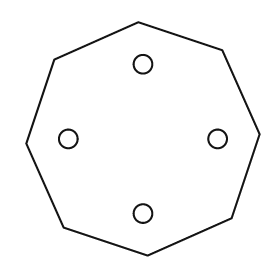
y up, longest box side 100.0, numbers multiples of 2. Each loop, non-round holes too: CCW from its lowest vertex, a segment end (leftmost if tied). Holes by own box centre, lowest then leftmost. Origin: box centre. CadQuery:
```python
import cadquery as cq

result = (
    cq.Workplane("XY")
    .moveTo(2.0, -50.0)
    .lineTo(38.0, -34.0)
    .lineTo(50.0, 2.0)
    .lineTo(34.0, 38.0)
    .lineTo(-2.0, 50.0)
    .lineTo(-38.0, 34.0)
    .lineTo(-50.0, -2.0)
    .lineTo(-34.0, -38.0)
    .close()
    .moveTo(0.0, -32.0)
    .circle(4.0)
    .moveTo(-32.0, 0.0)
    .circle(4.0)
    .moveTo(32.0, 0.0)
    .circle(4.0)
    .moveTo(0.0, 32.0)
    .circle(4.0)
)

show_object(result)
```